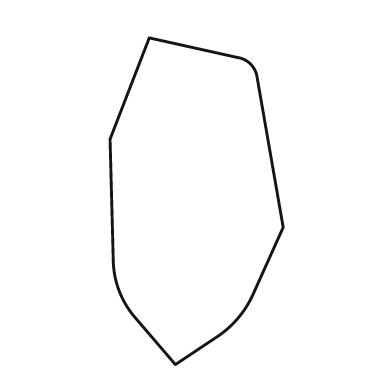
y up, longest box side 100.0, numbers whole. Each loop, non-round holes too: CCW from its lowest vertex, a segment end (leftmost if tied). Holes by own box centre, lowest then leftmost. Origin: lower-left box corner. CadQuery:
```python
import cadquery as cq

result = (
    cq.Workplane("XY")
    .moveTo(20.0, 0.0)
    .lineTo(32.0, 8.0)
    .threePointArc((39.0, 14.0), (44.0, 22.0))
    .lineTo(53.0, 42.0)
    .lineTo(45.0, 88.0)
    .threePointArc((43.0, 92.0), (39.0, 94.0))
    .lineTo(12.0, 100.0)
    .lineTo(0.0, 69.0)
    .lineTo(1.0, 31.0)
    .threePointArc((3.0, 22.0), (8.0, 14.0))
    .close()
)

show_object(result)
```